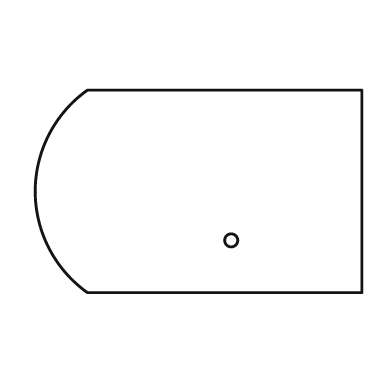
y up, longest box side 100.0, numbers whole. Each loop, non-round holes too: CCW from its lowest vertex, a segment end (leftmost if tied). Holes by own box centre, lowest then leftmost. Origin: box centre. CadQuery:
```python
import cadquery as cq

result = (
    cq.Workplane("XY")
    .moveTo(-34.0, -31.0)
    .lineTo(50.0, -31.0)
    .lineTo(50.0, 31.0)
    .lineTo(-34.0, 31.0)
    .threePointArc((-50.0, 0.0), (-34.0, -31.0))
    .close()
    .moveTo(10.0, -15.0)
    .circle(2.0)
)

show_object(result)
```